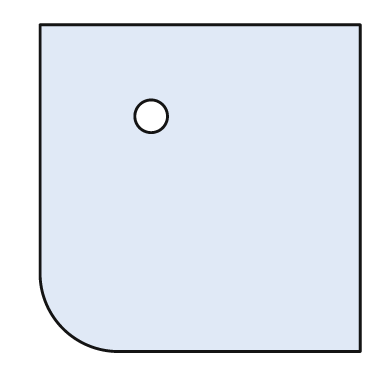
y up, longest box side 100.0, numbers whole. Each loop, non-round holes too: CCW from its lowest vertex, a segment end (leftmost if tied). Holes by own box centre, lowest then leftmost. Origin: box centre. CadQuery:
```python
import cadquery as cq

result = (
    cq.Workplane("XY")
    .moveTo(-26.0, -50.0)
    .lineTo(49.0, -50.0)
    .lineTo(49.0, 50.0)
    .lineTo(-49.0, 50.0)
    .lineTo(-49.0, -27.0)
    .threePointArc((-42.0, -43.0), (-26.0, -50.0))
    .close()
    .moveTo(-15.0, 22.0)
    .circle(5.0)
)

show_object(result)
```